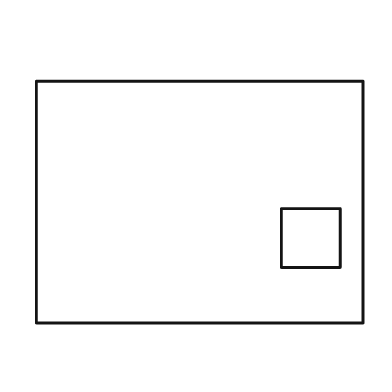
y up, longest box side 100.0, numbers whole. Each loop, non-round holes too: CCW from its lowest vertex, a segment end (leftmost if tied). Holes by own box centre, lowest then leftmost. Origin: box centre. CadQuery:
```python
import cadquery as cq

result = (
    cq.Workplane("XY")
    .moveTo(-50.0, -37.0)
    .lineTo(50.0, -37.0)
    .lineTo(50.0, 37.0)
    .lineTo(-50.0, 37.0)
    .close()
    .moveTo(25.0, -20.0)
    .lineTo(43.0, -20.0)
    .lineTo(43.0, -2.0)
    .lineTo(25.0, -2.0)
    .close()
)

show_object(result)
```